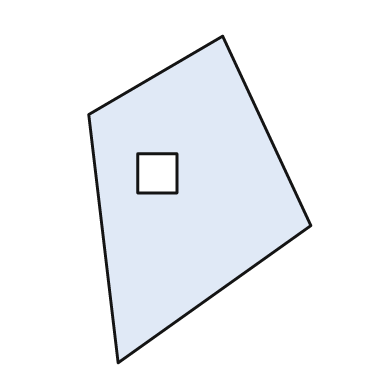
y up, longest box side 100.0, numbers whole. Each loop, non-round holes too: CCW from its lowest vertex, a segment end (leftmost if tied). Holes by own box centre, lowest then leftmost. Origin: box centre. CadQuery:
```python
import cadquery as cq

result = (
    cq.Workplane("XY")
    .moveTo(-25.0, -50.0)
    .lineTo(34.0, -8.0)
    .lineTo(7.0, 50.0)
    .lineTo(-34.0, 26.0)
    .close()
    .moveTo(-19.0, 2.0)
    .lineTo(-7.0, 2.0)
    .lineTo(-7.0, 14.0)
    .lineTo(-19.0, 14.0)
    .close()
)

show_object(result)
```